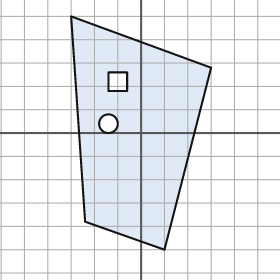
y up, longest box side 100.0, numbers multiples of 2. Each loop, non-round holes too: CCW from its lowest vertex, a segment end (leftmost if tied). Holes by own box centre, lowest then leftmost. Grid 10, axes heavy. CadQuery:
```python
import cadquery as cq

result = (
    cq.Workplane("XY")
    .moveTo(10.0, -50.0)
    .lineTo(30.0, 28.0)
    .lineTo(-30.0, 50.0)
    .lineTo(-24.0, -38.0)
    .close()
    .moveTo(-14.0, 4.0)
    .circle(4.0)
    .moveTo(-14.0, 18.0)
    .lineTo(-6.0, 18.0)
    .lineTo(-6.0, 26.0)
    .lineTo(-14.0, 26.0)
    .close()
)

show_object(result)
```